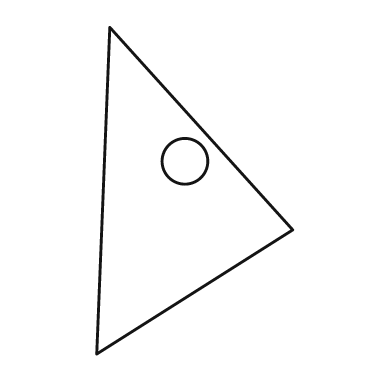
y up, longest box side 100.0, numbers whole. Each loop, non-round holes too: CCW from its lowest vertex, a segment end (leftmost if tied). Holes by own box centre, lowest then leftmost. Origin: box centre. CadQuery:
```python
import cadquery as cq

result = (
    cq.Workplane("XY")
    .moveTo(-30.0, -50.0)
    .lineTo(30.0, -12.0)
    .lineTo(-26.0, 50.0)
    .close()
    .moveTo(-3.0, 9.0)
    .circle(7.0)
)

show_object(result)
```